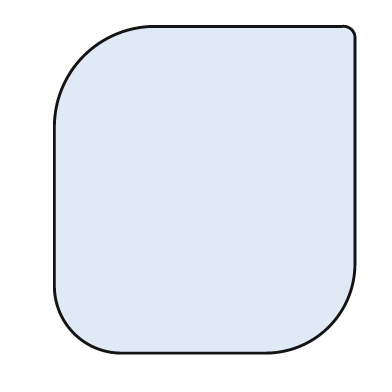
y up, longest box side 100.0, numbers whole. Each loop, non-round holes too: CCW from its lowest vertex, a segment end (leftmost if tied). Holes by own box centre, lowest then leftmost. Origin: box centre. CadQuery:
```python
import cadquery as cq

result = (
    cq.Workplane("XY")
    .moveTo(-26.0, -50.0)
    .lineTo(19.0, -50.0)
    .threePointArc((38.0, -42.0), (46.0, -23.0))
    .lineTo(46.0, 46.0)
    .threePointArc((45.0, 49.0), (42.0, 50.0))
    .lineTo(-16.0, 50.0)
    .threePointArc((-37.0, 41.0), (-46.0, 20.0))
    .lineTo(-46.0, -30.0)
    .threePointArc((-40.0, -44.0), (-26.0, -50.0))
    .close()
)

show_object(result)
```